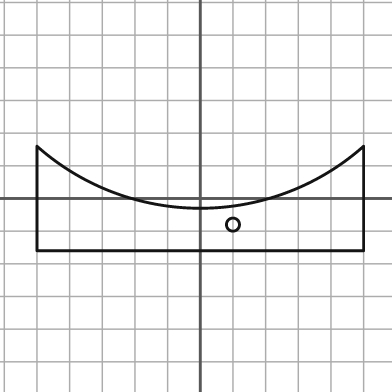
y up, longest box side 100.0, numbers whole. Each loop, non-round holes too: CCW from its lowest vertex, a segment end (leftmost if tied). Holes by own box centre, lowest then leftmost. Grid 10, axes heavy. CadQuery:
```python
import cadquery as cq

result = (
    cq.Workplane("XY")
    .moveTo(-50.0, -16.0)
    .lineTo(50.0, -16.0)
    .lineTo(50.0, 16.0)
    .threePointArc((0.0, -3.0), (-50.0, 16.0))
    .close()
    .moveTo(10.0, -8.0)
    .circle(2.0)
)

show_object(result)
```